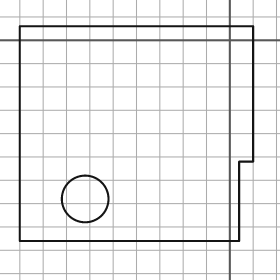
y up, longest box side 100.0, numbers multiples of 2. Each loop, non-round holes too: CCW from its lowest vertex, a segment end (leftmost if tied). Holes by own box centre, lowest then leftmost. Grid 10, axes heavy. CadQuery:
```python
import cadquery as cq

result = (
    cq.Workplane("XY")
    .moveTo(-90.0, -86.0)
    .lineTo(4.0, -86.0)
    .lineTo(4.0, -52.0)
    .lineTo(10.0, -52.0)
    .lineTo(10.0, 6.0)
    .lineTo(-90.0, 6.0)
    .close()
    .moveTo(-62.0, -68.0)
    .circle(10.0)
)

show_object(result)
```